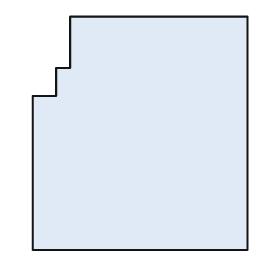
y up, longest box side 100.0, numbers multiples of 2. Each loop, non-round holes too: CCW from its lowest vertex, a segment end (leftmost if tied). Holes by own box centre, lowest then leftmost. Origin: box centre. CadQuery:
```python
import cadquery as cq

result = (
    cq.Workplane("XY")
    .moveTo(-46.0, -50.0)
    .lineTo(46.0, -50.0)
    .lineTo(46.0, 50.0)
    .lineTo(-30.0, 50.0)
    .lineTo(-30.0, 28.0)
    .lineTo(-36.0, 28.0)
    .lineTo(-36.0, 16.0)
    .lineTo(-46.0, 16.0)
    .close()
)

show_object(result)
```